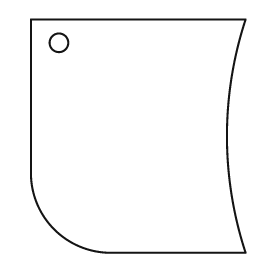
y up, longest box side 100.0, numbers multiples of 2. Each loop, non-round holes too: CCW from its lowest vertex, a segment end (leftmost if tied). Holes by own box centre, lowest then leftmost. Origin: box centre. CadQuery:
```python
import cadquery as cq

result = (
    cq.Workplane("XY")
    .moveTo(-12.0, -50.0)
    .lineTo(46.0, -50.0)
    .threePointArc((38.0, 0.0), (46.0, 50.0))
    .lineTo(-46.0, 50.0)
    .lineTo(-46.0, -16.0)
    .threePointArc((-36.0, -40.0), (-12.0, -50.0))
    .close()
    .moveTo(-34.0, 40.0)
    .circle(4.0)
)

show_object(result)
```